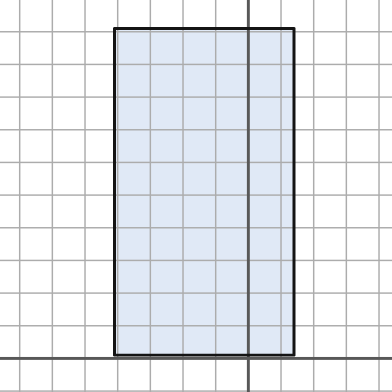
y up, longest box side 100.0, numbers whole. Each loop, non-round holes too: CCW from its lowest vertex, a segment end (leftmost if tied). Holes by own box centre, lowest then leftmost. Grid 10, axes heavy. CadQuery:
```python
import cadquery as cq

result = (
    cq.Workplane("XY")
    .moveTo(-41.0, 1.0)
    .lineTo(14.0, 1.0)
    .lineTo(14.0, 101.0)
    .lineTo(-41.0, 101.0)
    .close()
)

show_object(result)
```